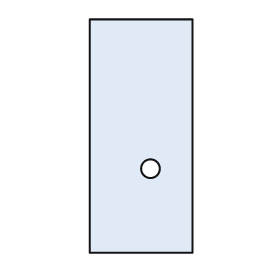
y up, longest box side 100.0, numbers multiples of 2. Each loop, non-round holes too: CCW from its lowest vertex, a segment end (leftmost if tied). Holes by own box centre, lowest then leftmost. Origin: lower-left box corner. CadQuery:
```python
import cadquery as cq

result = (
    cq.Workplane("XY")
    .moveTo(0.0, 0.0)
    .lineTo(44.0, 0.0)
    .lineTo(44.0, 100.0)
    .lineTo(0.0, 100.0)
    .close()
    .moveTo(26.0, 36.0)
    .circle(4.0)
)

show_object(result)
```